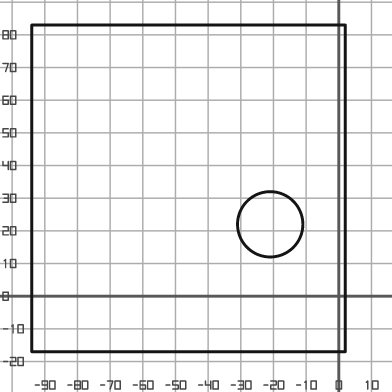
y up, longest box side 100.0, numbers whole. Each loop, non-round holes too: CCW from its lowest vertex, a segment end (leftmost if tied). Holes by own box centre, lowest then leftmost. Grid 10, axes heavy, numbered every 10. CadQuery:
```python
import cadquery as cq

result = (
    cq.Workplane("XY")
    .moveTo(-94.0, -17.0)
    .lineTo(2.0, -17.0)
    .lineTo(2.0, 83.0)
    .lineTo(-94.0, 83.0)
    .close()
    .moveTo(-21.0, 22.0)
    .circle(10.0)
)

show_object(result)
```